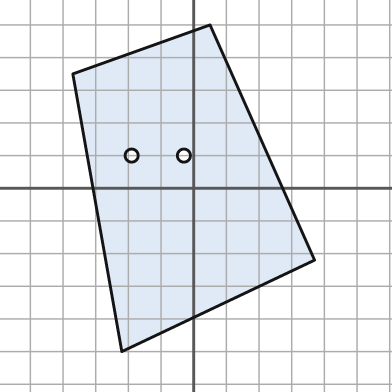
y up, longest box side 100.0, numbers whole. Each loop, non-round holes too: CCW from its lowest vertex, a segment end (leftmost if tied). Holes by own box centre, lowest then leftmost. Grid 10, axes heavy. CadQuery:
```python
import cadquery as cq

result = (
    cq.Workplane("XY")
    .moveTo(-22.0, -50.0)
    .lineTo(37.0, -22.0)
    .lineTo(5.0, 50.0)
    .lineTo(-37.0, 35.0)
    .close()
    .moveTo(-19.0, 10.0)
    .circle(2.0)
    .moveTo(-3.0, 10.0)
    .circle(2.0)
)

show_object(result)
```